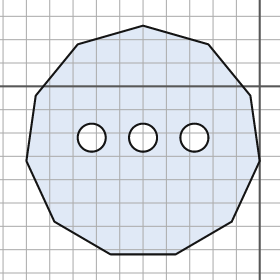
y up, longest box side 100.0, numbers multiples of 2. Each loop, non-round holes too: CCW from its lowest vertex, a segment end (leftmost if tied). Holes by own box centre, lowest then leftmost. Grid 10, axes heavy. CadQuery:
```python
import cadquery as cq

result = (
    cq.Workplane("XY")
    .moveTo(-64.0, -72.0)
    .lineTo(-36.0, -72.0)
    .lineTo(-12.0, -58.0)
    .lineTo(0.0, -32.0)
    .lineTo(-4.0, -4.0)
    .lineTo(-22.0, 18.0)
    .lineTo(-50.0, 26.0)
    .lineTo(-78.0, 18.0)
    .lineTo(-96.0, -4.0)
    .lineTo(-100.0, -32.0)
    .lineTo(-88.0, -58.0)
    .close()
    .moveTo(-72.0, -22.0)
    .circle(6.0)
    .moveTo(-50.0, -22.0)
    .circle(6.0)
    .moveTo(-28.0, -22.0)
    .circle(6.0)
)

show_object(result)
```